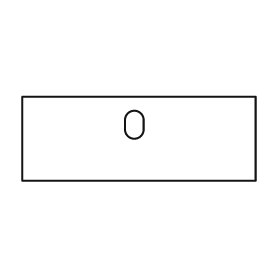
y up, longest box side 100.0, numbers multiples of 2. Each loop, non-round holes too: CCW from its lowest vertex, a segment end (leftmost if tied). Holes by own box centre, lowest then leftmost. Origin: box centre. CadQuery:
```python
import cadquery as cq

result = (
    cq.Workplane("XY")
    .moveTo(-50.0, -18.0)
    .lineTo(50.0, -18.0)
    .lineTo(50.0, 18.0)
    .lineTo(-50.0, 18.0)
    .close()
    .moveTo(-6.0, 4.0)
    .threePointArc((-2.0, 0.0), (2.0, 4.0))
    .lineTo(2.0, 8.0)
    .threePointArc((-2.0, 12.0), (-6.0, 8.0))
    .close()
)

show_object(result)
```